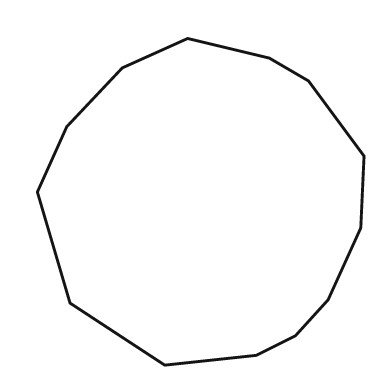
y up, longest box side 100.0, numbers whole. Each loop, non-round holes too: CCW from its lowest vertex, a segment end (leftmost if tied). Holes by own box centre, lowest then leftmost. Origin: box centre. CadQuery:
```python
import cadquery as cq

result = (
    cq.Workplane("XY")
    .moveTo(-11.0, -50.0)
    .lineTo(17.0, -47.0)
    .lineTo(29.0, -41.0)
    .lineTo(39.0, -30.0)
    .lineTo(49.0, -8.0)
    .lineTo(50.0, 14.0)
    .lineTo(33.0, 37.0)
    .lineTo(21.0, 44.0)
    .lineTo(-4.0, 50.0)
    .lineTo(-24.0, 41.0)
    .lineTo(-41.0, 23.0)
    .lineTo(-50.0, 3.0)
    .lineTo(-40.0, -31.0)
    .close()
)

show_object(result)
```